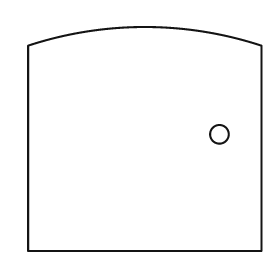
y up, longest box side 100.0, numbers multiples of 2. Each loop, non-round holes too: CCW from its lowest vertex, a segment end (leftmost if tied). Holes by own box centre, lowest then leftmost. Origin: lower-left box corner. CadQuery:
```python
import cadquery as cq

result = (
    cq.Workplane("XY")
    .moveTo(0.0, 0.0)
    .lineTo(100.0, 0.0)
    .lineTo(100.0, 88.0)
    .threePointArc((50.0, 96.0), (0.0, 88.0))
    .close()
    .moveTo(82.0, 50.0)
    .circle(4.0)
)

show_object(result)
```